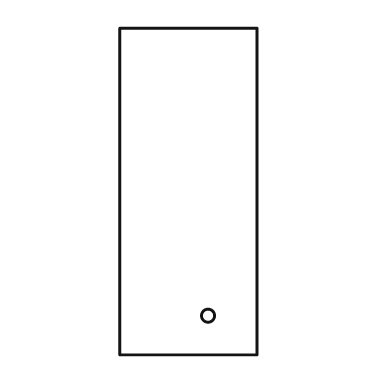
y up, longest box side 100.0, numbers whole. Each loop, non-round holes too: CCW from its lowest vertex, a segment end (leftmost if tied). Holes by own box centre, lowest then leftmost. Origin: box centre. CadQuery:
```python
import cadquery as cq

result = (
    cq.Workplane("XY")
    .moveTo(-21.0, -50.0)
    .lineTo(21.0, -50.0)
    .lineTo(21.0, 50.0)
    .lineTo(-21.0, 50.0)
    .close()
    .moveTo(6.0, -38.0)
    .circle(2.0)
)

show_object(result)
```